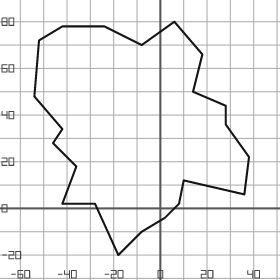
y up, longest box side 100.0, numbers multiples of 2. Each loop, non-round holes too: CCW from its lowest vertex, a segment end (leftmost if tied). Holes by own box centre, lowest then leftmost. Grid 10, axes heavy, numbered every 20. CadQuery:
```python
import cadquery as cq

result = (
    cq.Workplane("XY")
    .moveTo(-18.0, -20.0)
    .lineTo(-8.0, -10.0)
    .lineTo(2.0, -4.0)
    .lineTo(8.0, 2.0)
    .lineTo(10.0, 12.0)
    .lineTo(36.0, 6.0)
    .lineTo(38.0, 22.0)
    .lineTo(28.0, 36.0)
    .lineTo(28.0, 44.0)
    .lineTo(14.0, 50.0)
    .lineTo(18.0, 66.0)
    .lineTo(6.0, 80.0)
    .lineTo(-8.0, 70.0)
    .lineTo(-24.0, 78.0)
    .lineTo(-42.0, 78.0)
    .lineTo(-52.0, 72.0)
    .lineTo(-54.0, 48.0)
    .lineTo(-42.0, 34.0)
    .lineTo(-46.0, 28.0)
    .lineTo(-36.0, 18.0)
    .lineTo(-42.0, 2.0)
    .lineTo(-28.0, 2.0)
    .close()
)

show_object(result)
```